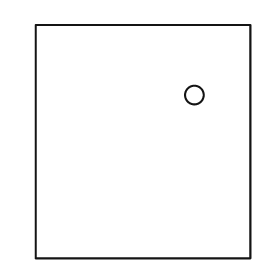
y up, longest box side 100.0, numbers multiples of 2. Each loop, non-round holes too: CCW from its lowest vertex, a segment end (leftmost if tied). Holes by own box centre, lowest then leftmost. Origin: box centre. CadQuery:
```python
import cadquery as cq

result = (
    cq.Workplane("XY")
    .moveTo(-46.0, -50.0)
    .lineTo(46.0, -50.0)
    .lineTo(46.0, 50.0)
    .lineTo(-46.0, 50.0)
    .close()
    .moveTo(22.0, 20.0)
    .circle(4.0)
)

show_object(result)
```